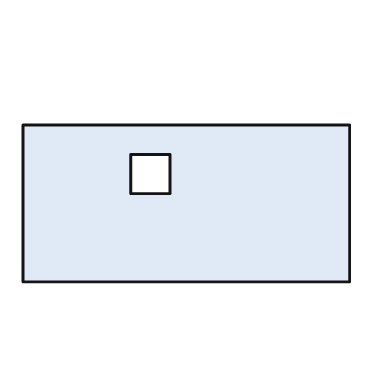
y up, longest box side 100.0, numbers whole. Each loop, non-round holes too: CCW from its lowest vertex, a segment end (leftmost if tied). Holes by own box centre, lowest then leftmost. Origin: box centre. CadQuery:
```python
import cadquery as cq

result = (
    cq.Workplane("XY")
    .moveTo(-50.0, -24.0)
    .lineTo(50.0, -24.0)
    .lineTo(50.0, 24.0)
    .lineTo(-50.0, 24.0)
    .close()
    .moveTo(-17.0, 3.0)
    .lineTo(-5.0, 3.0)
    .lineTo(-5.0, 15.0)
    .lineTo(-17.0, 15.0)
    .close()
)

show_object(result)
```